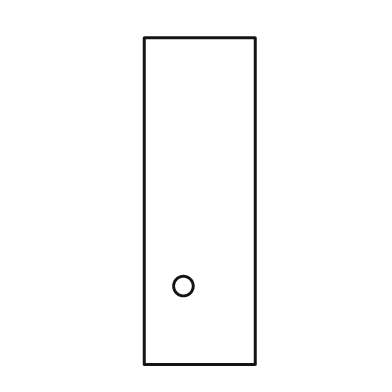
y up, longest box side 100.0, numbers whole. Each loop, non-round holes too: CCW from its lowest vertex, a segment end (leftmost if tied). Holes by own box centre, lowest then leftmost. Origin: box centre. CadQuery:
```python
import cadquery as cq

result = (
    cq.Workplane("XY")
    .moveTo(-17.0, -50.0)
    .lineTo(17.0, -50.0)
    .lineTo(17.0, 50.0)
    .lineTo(-17.0, 50.0)
    .close()
    .moveTo(-5.0, -26.0)
    .circle(3.0)
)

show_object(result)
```